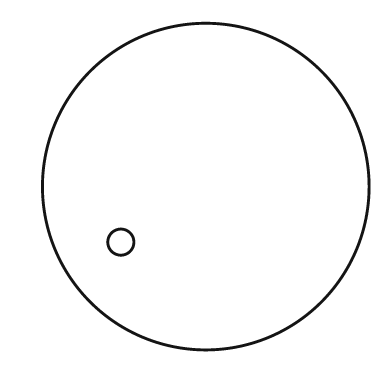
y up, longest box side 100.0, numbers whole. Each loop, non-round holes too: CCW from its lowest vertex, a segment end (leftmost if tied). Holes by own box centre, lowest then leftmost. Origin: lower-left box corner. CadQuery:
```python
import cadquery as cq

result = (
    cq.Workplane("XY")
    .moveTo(50.0, 50.0)
    .circle(50.0)
    .moveTo(24.0, 33.0)
    .circle(4.0)
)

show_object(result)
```